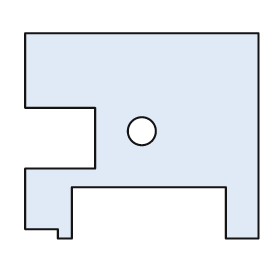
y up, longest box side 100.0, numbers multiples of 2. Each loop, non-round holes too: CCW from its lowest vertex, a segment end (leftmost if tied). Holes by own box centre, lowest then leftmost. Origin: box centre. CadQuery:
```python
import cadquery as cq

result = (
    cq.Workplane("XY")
    .moveTo(-36.0, -44.0)
    .lineTo(-30.0, -44.0)
    .lineTo(-30.0, -22.0)
    .lineTo(36.0, -22.0)
    .lineTo(36.0, -44.0)
    .lineTo(50.0, -44.0)
    .lineTo(50.0, 44.0)
    .lineTo(-50.0, 44.0)
    .lineTo(-50.0, 12.0)
    .lineTo(-20.0, 12.0)
    .lineTo(-20.0, -14.0)
    .lineTo(-50.0, -14.0)
    .lineTo(-50.0, -40.0)
    .lineTo(-36.0, -40.0)
    .close()
    .moveTo(0.0, 2.0)
    .circle(6.0)
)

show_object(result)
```